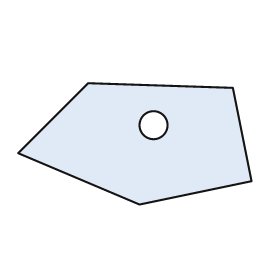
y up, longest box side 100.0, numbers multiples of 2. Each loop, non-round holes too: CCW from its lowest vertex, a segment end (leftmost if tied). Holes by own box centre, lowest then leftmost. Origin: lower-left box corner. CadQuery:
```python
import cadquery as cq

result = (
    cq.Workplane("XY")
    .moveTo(52.0, 0.0)
    .lineTo(100.0, 10.0)
    .lineTo(92.0, 50.0)
    .lineTo(30.0, 52.0)
    .lineTo(0.0, 22.0)
    .close()
    .moveTo(58.0, 34.0)
    .circle(6.0)
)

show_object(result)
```